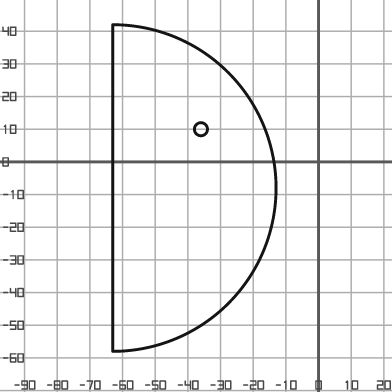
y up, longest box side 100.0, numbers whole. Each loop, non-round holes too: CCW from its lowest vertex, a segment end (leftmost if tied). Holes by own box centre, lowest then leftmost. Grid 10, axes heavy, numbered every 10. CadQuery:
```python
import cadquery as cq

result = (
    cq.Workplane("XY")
    .moveTo(-63.0, -58.0)
    .threePointArc((-13.0, -8.0), (-63.0, 42.0))
    .close()
    .moveTo(-36.0, 10.0)
    .circle(2.0)
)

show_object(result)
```